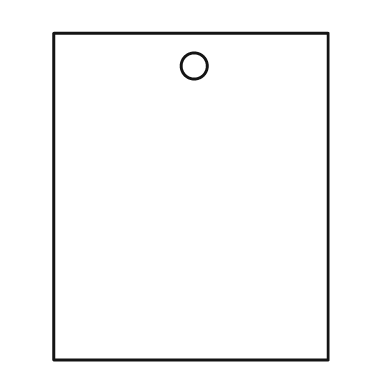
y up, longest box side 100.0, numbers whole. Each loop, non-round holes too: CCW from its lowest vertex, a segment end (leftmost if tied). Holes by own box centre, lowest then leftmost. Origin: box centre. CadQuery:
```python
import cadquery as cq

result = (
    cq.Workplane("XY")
    .moveTo(-42.0, -50.0)
    .lineTo(42.0, -50.0)
    .lineTo(42.0, 50.0)
    .lineTo(-42.0, 50.0)
    .close()
    .moveTo(1.0, 40.0)
    .circle(4.0)
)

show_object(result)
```